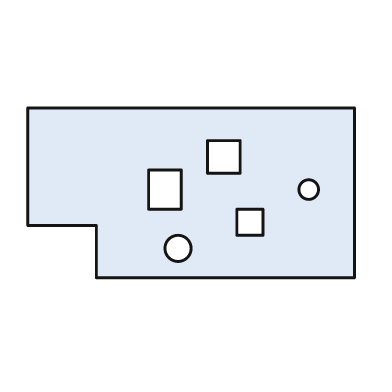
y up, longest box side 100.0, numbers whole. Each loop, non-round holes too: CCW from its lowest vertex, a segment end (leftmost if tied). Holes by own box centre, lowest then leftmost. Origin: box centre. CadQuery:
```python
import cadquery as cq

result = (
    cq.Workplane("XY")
    .moveTo(-29.0, -26.0)
    .lineTo(50.0, -26.0)
    .lineTo(50.0, 26.0)
    .lineTo(-50.0, 26.0)
    .lineTo(-50.0, -10.0)
    .lineTo(-29.0, -10.0)
    .close()
    .moveTo(-4.0, -17.0)
    .circle(4.0)
    .moveTo(14.0, -13.0)
    .lineTo(22.0, -13.0)
    .lineTo(22.0, -5.0)
    .lineTo(14.0, -5.0)
    .close()
    .moveTo(-13.0, -5.0)
    .lineTo(-3.0, -5.0)
    .lineTo(-3.0, 7.0)
    .lineTo(-13.0, 7.0)
    .close()
    .moveTo(36.0, 1.0)
    .circle(3.0)
    .moveTo(5.0, 6.0)
    .lineTo(15.0, 6.0)
    .lineTo(15.0, 16.0)
    .lineTo(5.0, 16.0)
    .close()
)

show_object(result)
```